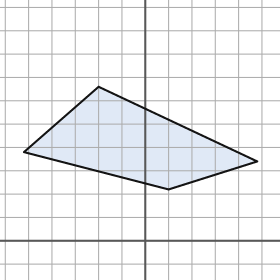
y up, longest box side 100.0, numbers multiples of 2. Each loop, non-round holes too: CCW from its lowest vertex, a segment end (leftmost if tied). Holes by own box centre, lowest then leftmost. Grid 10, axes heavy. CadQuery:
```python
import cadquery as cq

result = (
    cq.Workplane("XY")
    .moveTo(10.0, 22.0)
    .lineTo(48.0, 34.0)
    .lineTo(-20.0, 66.0)
    .lineTo(-52.0, 38.0)
    .close()
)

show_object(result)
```